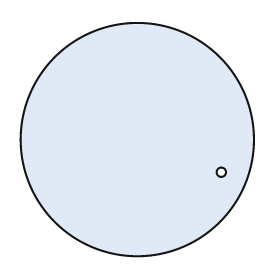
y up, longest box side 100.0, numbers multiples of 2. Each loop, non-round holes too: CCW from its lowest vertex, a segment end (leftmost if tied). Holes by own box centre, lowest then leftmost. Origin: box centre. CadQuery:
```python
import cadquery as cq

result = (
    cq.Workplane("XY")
    .moveTo(0.0, 0.0)
    .circle(50.0)
    .moveTo(36.0, -14.0)
    .circle(2.0)
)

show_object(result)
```